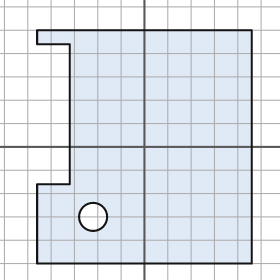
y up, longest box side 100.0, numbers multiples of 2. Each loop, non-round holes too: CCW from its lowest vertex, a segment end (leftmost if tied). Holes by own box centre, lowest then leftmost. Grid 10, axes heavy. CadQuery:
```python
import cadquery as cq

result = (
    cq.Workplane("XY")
    .moveTo(-46.0, -50.0)
    .lineTo(46.0, -50.0)
    .lineTo(46.0, 50.0)
    .lineTo(-46.0, 50.0)
    .lineTo(-46.0, 44.0)
    .lineTo(-32.0, 44.0)
    .lineTo(-32.0, -16.0)
    .lineTo(-46.0, -16.0)
    .close()
    .moveTo(-22.0, -30.0)
    .circle(6.0)
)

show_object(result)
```